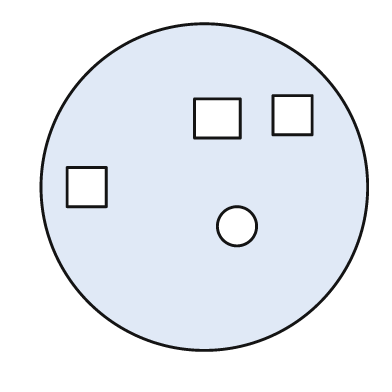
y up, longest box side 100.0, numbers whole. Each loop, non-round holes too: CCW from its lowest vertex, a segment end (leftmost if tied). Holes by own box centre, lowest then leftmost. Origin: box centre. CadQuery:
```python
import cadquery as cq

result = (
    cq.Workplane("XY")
    .moveTo(0.0, 0.0)
    .circle(50.0)
    .moveTo(10.0, -12.0)
    .circle(6.0)
    .moveTo(-42.0, -6.0)
    .lineTo(-30.0, -6.0)
    .lineTo(-30.0, 6.0)
    .lineTo(-42.0, 6.0)
    .close()
    .moveTo(-3.0, 15.0)
    .lineTo(11.0, 15.0)
    .lineTo(11.0, 27.0)
    .lineTo(-3.0, 27.0)
    .close()
    .moveTo(21.0, 16.0)
    .lineTo(33.0, 16.0)
    .lineTo(33.0, 28.0)
    .lineTo(21.0, 28.0)
    .close()
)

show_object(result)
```